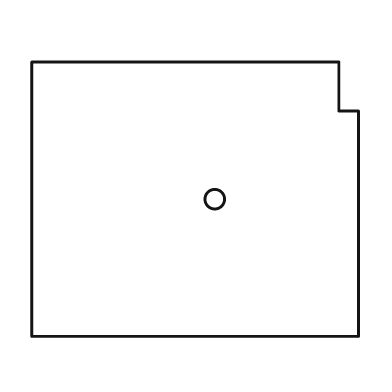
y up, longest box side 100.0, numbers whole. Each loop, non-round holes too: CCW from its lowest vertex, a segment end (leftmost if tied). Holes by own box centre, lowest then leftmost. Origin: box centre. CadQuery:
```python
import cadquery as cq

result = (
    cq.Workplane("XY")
    .moveTo(-50.0, -42.0)
    .lineTo(50.0, -42.0)
    .lineTo(50.0, 27.0)
    .lineTo(44.0, 27.0)
    .lineTo(44.0, 42.0)
    .lineTo(-50.0, 42.0)
    .close()
    .moveTo(6.0, 0.0)
    .circle(3.0)
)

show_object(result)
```